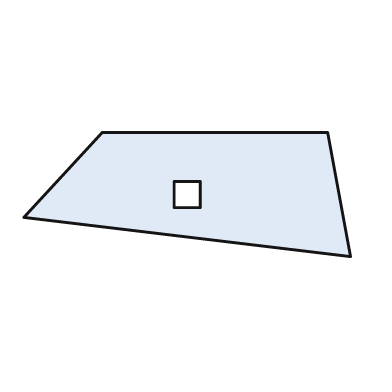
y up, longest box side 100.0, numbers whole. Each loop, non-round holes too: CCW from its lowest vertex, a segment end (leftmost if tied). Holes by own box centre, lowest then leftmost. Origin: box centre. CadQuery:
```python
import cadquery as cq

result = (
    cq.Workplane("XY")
    .moveTo(50.0, -19.0)
    .lineTo(43.0, 19.0)
    .lineTo(-26.0, 19.0)
    .lineTo(-50.0, -7.0)
    .close()
    .moveTo(-4.0, -4.0)
    .lineTo(4.0, -4.0)
    .lineTo(4.0, 4.0)
    .lineTo(-4.0, 4.0)
    .close()
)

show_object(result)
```